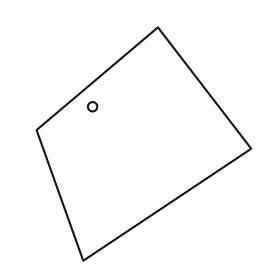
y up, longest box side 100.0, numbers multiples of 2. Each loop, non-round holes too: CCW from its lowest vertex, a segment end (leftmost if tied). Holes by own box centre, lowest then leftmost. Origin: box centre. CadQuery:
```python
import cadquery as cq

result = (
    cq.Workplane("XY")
    .moveTo(-26.0, -50.0)
    .lineTo(46.0, -2.0)
    .lineTo(6.0, 50.0)
    .lineTo(-46.0, 6.0)
    .close()
    .moveTo(-22.0, 16.0)
    .circle(2.0)
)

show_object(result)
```